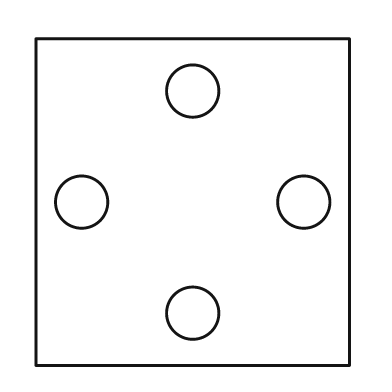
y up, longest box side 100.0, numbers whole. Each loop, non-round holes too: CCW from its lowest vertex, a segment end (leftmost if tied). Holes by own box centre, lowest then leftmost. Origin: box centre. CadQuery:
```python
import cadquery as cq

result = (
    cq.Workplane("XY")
    .moveTo(-48.0, -50.0)
    .lineTo(48.0, -50.0)
    .lineTo(48.0, 50.0)
    .lineTo(-48.0, 50.0)
    .close()
    .moveTo(0.0, -34.0)
    .circle(8.0)
    .moveTo(-34.0, 0.0)
    .circle(8.0)
    .moveTo(34.0, 0.0)
    .circle(8.0)
    .moveTo(0.0, 34.0)
    .circle(8.0)
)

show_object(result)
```